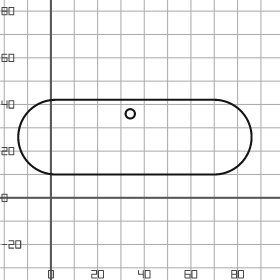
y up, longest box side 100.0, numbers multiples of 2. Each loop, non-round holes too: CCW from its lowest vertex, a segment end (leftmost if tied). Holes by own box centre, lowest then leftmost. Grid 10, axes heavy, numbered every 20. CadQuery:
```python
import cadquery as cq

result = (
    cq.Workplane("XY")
    .moveTo(2.0, 10.0)
    .lineTo(70.0, 10.0)
    .threePointArc((86.0, 26.0), (70.0, 42.0))
    .lineTo(2.0, 42.0)
    .threePointArc((-14.0, 26.0), (2.0, 10.0))
    .close()
    .moveTo(34.0, 36.0)
    .circle(2.0)
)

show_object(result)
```